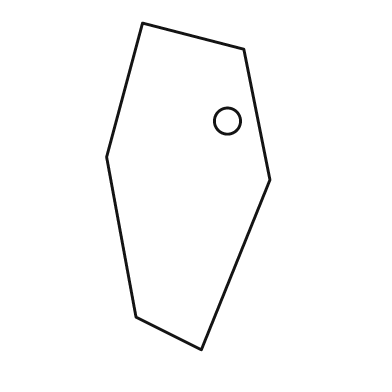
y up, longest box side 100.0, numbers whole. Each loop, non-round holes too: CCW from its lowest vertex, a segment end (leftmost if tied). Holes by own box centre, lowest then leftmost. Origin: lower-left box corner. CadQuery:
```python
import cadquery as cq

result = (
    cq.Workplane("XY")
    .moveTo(29.0, 0.0)
    .lineTo(50.0, 52.0)
    .lineTo(42.0, 92.0)
    .lineTo(11.0, 100.0)
    .lineTo(0.0, 59.0)
    .lineTo(9.0, 10.0)
    .close()
    .moveTo(37.0, 70.0)
    .circle(4.0)
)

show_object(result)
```